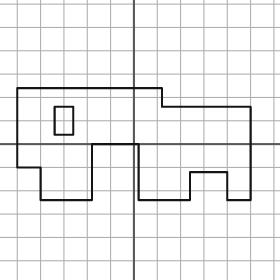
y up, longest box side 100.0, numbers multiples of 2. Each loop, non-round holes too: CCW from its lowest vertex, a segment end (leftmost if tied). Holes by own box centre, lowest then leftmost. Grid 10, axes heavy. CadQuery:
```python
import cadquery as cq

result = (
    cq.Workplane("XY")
    .moveTo(-40.0, -24.0)
    .lineTo(-18.0, -24.0)
    .lineTo(-18.0, 0.0)
    .lineTo(2.0, 0.0)
    .lineTo(2.0, -24.0)
    .lineTo(24.0, -24.0)
    .lineTo(24.0, -12.0)
    .lineTo(40.0, -12.0)
    .lineTo(40.0, -24.0)
    .lineTo(50.0, -24.0)
    .lineTo(50.0, 16.0)
    .lineTo(12.0, 16.0)
    .lineTo(12.0, 24.0)
    .lineTo(-50.0, 24.0)
    .lineTo(-50.0, -10.0)
    .lineTo(-40.0, -10.0)
    .close()
    .moveTo(-34.0, 4.0)
    .lineTo(-26.0, 4.0)
    .lineTo(-26.0, 16.0)
    .lineTo(-34.0, 16.0)
    .close()
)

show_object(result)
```